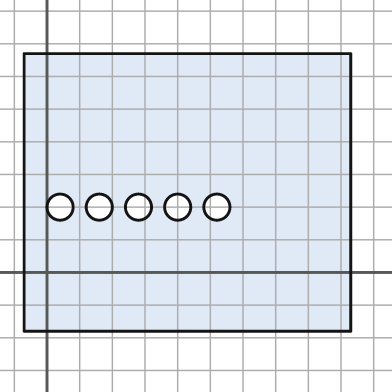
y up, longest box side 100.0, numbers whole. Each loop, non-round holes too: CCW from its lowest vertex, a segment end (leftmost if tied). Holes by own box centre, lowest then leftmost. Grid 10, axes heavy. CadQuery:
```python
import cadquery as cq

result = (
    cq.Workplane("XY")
    .moveTo(-7.0, -18.0)
    .lineTo(93.0, -18.0)
    .lineTo(93.0, 67.0)
    .lineTo(-7.0, 67.0)
    .close()
    .moveTo(4.0, 20.0)
    .circle(4.0)
    .moveTo(16.0, 20.0)
    .circle(4.0)
    .moveTo(28.0, 20.0)
    .circle(4.0)
    .moveTo(40.0, 20.0)
    .circle(4.0)
    .moveTo(52.0, 20.0)
    .circle(4.0)
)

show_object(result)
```